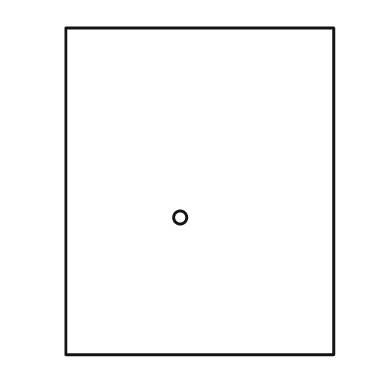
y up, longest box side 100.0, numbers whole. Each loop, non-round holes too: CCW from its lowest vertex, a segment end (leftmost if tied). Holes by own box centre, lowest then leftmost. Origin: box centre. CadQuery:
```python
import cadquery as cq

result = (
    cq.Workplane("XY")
    .moveTo(-41.0, -50.0)
    .lineTo(41.0, -50.0)
    .lineTo(41.0, 50.0)
    .lineTo(-41.0, 50.0)
    .close()
    .moveTo(-6.0, -8.0)
    .circle(2.0)
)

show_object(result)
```